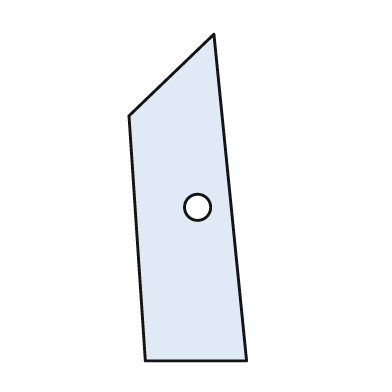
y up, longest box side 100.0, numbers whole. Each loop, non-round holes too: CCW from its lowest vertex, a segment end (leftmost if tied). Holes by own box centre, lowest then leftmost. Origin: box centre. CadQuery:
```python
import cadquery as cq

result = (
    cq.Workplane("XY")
    .moveTo(-13.0, -50.0)
    .lineTo(18.0, -50.0)
    .lineTo(8.0, 50.0)
    .lineTo(-18.0, 25.0)
    .close()
    .moveTo(3.0, -3.0)
    .circle(4.0)
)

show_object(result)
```